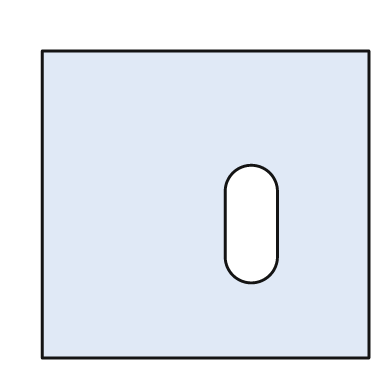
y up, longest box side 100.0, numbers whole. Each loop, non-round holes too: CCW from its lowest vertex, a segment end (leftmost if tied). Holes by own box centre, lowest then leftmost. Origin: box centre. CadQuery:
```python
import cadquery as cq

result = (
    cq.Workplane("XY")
    .moveTo(-50.0, -47.0)
    .lineTo(50.0, -47.0)
    .lineTo(50.0, 47.0)
    .lineTo(-50.0, 47.0)
    .close()
    .moveTo(6.0, -16.0)
    .threePointArc((14.0, -24.0), (22.0, -16.0))
    .lineTo(22.0, 4.0)
    .threePointArc((14.0, 12.0), (6.0, 4.0))
    .close()
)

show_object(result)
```